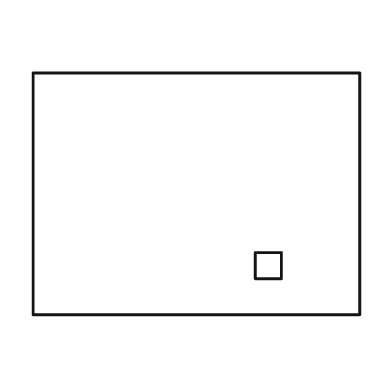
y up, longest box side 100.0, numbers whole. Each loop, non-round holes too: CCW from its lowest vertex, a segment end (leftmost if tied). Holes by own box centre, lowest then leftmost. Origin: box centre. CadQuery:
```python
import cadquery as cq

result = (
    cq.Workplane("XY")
    .moveTo(-50.0, -37.0)
    .lineTo(50.0, -37.0)
    .lineTo(50.0, 37.0)
    .lineTo(-50.0, 37.0)
    .close()
    .moveTo(18.0, -26.0)
    .lineTo(26.0, -26.0)
    .lineTo(26.0, -18.0)
    .lineTo(18.0, -18.0)
    .close()
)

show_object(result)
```